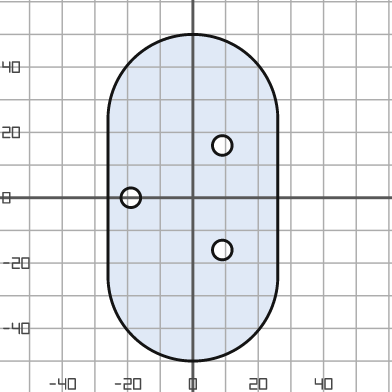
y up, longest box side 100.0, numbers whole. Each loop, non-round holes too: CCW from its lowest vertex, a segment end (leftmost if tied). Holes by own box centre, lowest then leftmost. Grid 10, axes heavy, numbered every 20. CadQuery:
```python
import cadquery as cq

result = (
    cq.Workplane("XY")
    .moveTo(-26.0, -24.0)
    .threePointArc((0.0, -50.0), (26.0, -24.0))
    .lineTo(26.0, 24.0)
    .threePointArc((0.0, 50.0), (-26.0, 24.0))
    .close()
    .moveTo(9.0, -16.0)
    .circle(3.0)
    .moveTo(-19.0, 0.0)
    .circle(3.0)
    .moveTo(9.0, 16.0)
    .circle(3.0)
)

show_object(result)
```